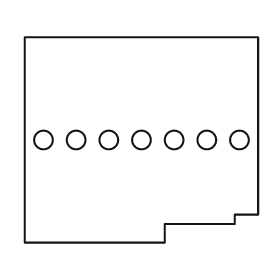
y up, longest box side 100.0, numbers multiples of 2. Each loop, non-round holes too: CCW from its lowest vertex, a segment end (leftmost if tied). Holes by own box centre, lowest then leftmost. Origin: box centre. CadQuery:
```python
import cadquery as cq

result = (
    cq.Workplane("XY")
    .moveTo(-50.0, -44.0)
    .lineTo(10.0, -44.0)
    .lineTo(10.0, -36.0)
    .lineTo(40.0, -36.0)
    .lineTo(40.0, -32.0)
    .lineTo(50.0, -32.0)
    .lineTo(50.0, 44.0)
    .lineTo(-50.0, 44.0)
    .close()
    .moveTo(-42.0, 0.0)
    .circle(4.0)
    .moveTo(-28.0, 0.0)
    .circle(4.0)
    .moveTo(-14.0, 0.0)
    .circle(4.0)
    .moveTo(0.0, 0.0)
    .circle(4.0)
    .moveTo(14.0, 0.0)
    .circle(4.0)
    .moveTo(28.0, 0.0)
    .circle(4.0)
    .moveTo(42.0, 0.0)
    .circle(4.0)
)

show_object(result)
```